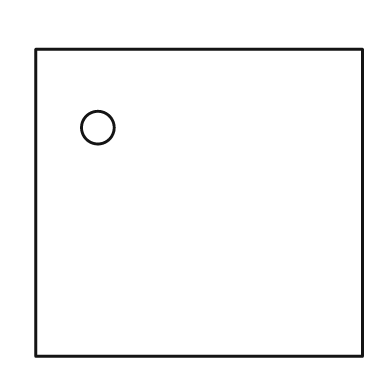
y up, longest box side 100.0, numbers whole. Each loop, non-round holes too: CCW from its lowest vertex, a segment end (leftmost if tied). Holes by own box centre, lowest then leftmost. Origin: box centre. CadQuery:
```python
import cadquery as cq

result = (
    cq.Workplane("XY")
    .moveTo(-50.0, -47.0)
    .lineTo(50.0, -47.0)
    .lineTo(50.0, 47.0)
    .lineTo(-50.0, 47.0)
    .close()
    .moveTo(-31.0, 23.0)
    .circle(5.0)
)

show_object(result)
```